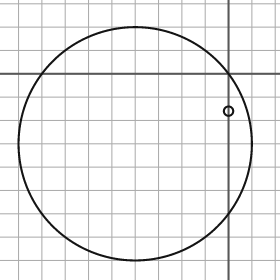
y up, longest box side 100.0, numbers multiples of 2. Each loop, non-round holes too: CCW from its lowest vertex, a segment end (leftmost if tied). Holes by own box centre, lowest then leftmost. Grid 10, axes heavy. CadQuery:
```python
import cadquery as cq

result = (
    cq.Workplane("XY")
    .moveTo(-40.0, -30.0)
    .circle(50.0)
    .moveTo(0.0, -16.0)
    .circle(2.0)
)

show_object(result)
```